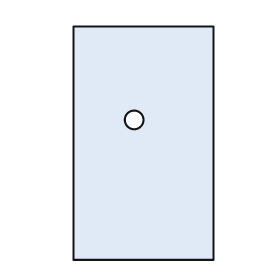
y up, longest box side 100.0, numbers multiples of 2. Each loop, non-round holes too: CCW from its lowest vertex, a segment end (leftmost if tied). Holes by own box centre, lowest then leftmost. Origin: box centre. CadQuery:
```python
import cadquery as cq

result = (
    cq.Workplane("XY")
    .moveTo(-30.0, -50.0)
    .lineTo(30.0, -50.0)
    .lineTo(30.0, 50.0)
    .lineTo(-30.0, 50.0)
    .close()
    .moveTo(-4.0, 10.0)
    .circle(4.0)
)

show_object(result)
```